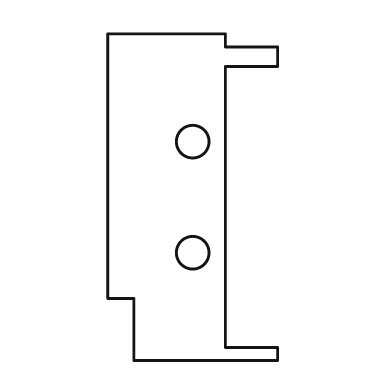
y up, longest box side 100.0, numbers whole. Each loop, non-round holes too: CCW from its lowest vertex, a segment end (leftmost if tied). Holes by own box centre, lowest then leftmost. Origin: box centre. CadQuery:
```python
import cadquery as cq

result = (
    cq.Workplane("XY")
    .moveTo(-18.0, -50.0)
    .lineTo(26.0, -50.0)
    .lineTo(26.0, -46.0)
    .lineTo(10.0, -46.0)
    .lineTo(10.0, 40.0)
    .lineTo(26.0, 40.0)
    .lineTo(26.0, 46.0)
    .lineTo(10.0, 46.0)
    .lineTo(10.0, 50.0)
    .lineTo(-26.0, 50.0)
    .lineTo(-26.0, -31.0)
    .lineTo(-18.0, -31.0)
    .close()
    .moveTo(0.0, -17.0)
    .circle(5.0)
    .moveTo(0.0, 17.0)
    .circle(5.0)
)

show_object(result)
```